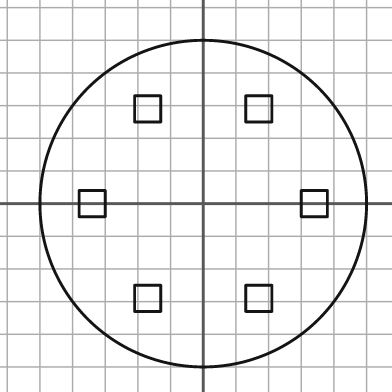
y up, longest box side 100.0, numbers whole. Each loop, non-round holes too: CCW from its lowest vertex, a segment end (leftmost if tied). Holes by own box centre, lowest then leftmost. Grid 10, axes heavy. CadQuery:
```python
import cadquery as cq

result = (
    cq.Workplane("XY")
    .moveTo(0.0, 0.0)
    .circle(50.0)
    .moveTo(-21.0, -33.0)
    .lineTo(-13.0, -33.0)
    .lineTo(-13.0, -25.0)
    .lineTo(-21.0, -25.0)
    .close()
    .moveTo(13.0, -33.0)
    .lineTo(21.0, -33.0)
    .lineTo(21.0, -25.0)
    .lineTo(13.0, -25.0)
    .close()
    .moveTo(-38.0, -4.0)
    .lineTo(-30.0, -4.0)
    .lineTo(-30.0, 4.0)
    .lineTo(-38.0, 4.0)
    .close()
    .moveTo(30.0, -4.0)
    .lineTo(38.0, -4.0)
    .lineTo(38.0, 4.0)
    .lineTo(30.0, 4.0)
    .close()
    .moveTo(-21.0, 25.0)
    .lineTo(-13.0, 25.0)
    .lineTo(-13.0, 33.0)
    .lineTo(-21.0, 33.0)
    .close()
    .moveTo(13.0, 25.0)
    .lineTo(21.0, 25.0)
    .lineTo(21.0, 33.0)
    .lineTo(13.0, 33.0)
    .close()
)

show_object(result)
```